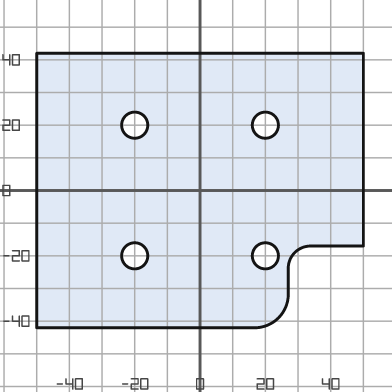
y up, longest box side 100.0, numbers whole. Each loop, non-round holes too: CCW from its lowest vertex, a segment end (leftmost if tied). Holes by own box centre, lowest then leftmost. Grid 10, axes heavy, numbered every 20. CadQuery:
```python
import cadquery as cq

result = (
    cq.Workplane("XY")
    .moveTo(-50.0, -42.0)
    .lineTo(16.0, -42.0)
    .threePointArc((24.0, -39.0), (27.0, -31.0))
    .lineTo(27.0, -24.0)
    .threePointArc((29.0, -19.0), (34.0, -17.0))
    .lineTo(50.0, -17.0)
    .lineTo(50.0, 42.0)
    .lineTo(-50.0, 42.0)
    .close()
    .moveTo(-20.0, -20.0)
    .circle(4.0)
    .moveTo(20.0, -20.0)
    .circle(4.0)
    .moveTo(-20.0, 20.0)
    .circle(4.0)
    .moveTo(20.0, 20.0)
    .circle(4.0)
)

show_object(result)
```